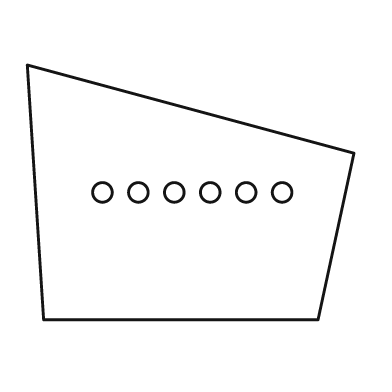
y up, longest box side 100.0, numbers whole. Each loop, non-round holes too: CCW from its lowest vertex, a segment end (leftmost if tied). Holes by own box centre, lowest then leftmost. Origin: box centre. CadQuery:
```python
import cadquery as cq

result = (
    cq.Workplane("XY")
    .moveTo(-45.0, -39.0)
    .lineTo(39.0, -39.0)
    .lineTo(50.0, 12.0)
    .lineTo(-50.0, 39.0)
    .close()
    .moveTo(-27.0, 0.0)
    .circle(3.0)
    .moveTo(-16.0, 0.0)
    .circle(3.0)
    .moveTo(-5.0, 0.0)
    .circle(3.0)
    .moveTo(6.0, 0.0)
    .circle(3.0)
    .moveTo(17.0, 0.0)
    .circle(3.0)
    .moveTo(28.0, 0.0)
    .circle(3.0)
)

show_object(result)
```